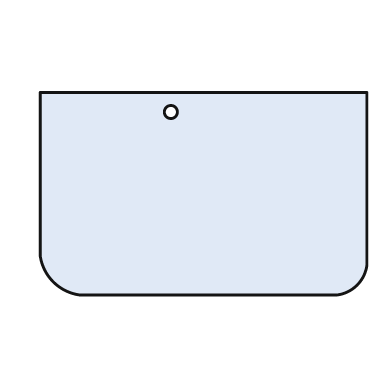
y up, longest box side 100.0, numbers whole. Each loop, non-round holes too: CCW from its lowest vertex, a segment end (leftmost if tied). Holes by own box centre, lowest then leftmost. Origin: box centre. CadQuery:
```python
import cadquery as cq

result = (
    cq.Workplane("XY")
    .moveTo(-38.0, -31.0)
    .lineTo(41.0, -31.0)
    .threePointArc((47.0, -28.0), (50.0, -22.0))
    .lineTo(50.0, 31.0)
    .lineTo(-50.0, 31.0)
    .lineTo(-50.0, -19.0)
    .threePointArc((-46.0, -27.0), (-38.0, -31.0))
    .close()
    .moveTo(-10.0, 25.0)
    .circle(2.0)
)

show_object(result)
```